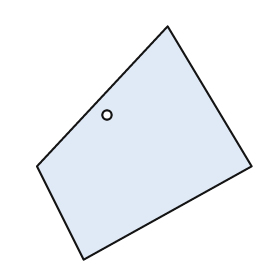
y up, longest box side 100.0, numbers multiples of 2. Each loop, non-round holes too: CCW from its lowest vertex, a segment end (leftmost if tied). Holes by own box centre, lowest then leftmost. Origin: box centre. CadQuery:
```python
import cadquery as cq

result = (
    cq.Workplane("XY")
    .moveTo(-26.0, -50.0)
    .lineTo(46.0, -10.0)
    .lineTo(10.0, 50.0)
    .lineTo(-46.0, -10.0)
    .close()
    .moveTo(-16.0, 12.0)
    .circle(2.0)
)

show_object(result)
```